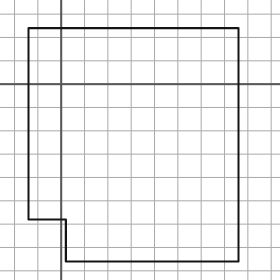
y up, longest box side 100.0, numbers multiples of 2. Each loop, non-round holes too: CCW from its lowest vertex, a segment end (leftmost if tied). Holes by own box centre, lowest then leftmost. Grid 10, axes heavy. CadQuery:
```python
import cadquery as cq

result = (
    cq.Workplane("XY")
    .moveTo(2.0, -76.0)
    .lineTo(76.0, -76.0)
    .lineTo(76.0, 24.0)
    .lineTo(-14.0, 24.0)
    .lineTo(-14.0, -58.0)
    .lineTo(2.0, -58.0)
    .close()
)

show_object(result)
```